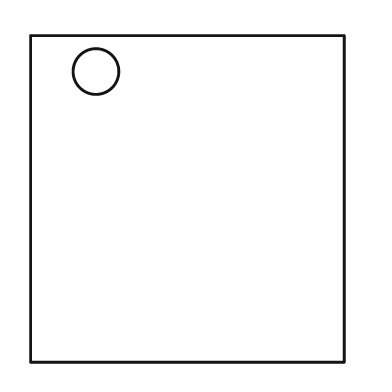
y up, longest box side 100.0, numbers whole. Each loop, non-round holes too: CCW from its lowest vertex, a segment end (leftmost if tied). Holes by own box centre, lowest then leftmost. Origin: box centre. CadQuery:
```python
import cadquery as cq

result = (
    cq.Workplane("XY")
    .moveTo(-48.0, -50.0)
    .lineTo(48.0, -50.0)
    .lineTo(48.0, 50.0)
    .lineTo(-48.0, 50.0)
    .close()
    .moveTo(-28.0, 39.0)
    .circle(7.0)
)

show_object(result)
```